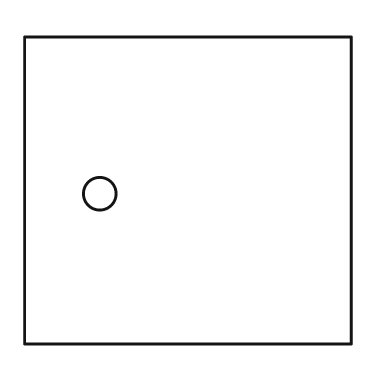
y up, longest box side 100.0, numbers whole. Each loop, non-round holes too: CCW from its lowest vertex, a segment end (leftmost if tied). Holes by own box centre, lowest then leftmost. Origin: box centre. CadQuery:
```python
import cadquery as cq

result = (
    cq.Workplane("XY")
    .moveTo(-50.0, -47.0)
    .lineTo(50.0, -47.0)
    .lineTo(50.0, 47.0)
    .lineTo(-50.0, 47.0)
    .close()
    .moveTo(-27.0, -1.0)
    .circle(5.0)
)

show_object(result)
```